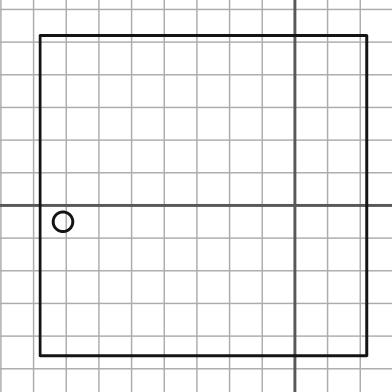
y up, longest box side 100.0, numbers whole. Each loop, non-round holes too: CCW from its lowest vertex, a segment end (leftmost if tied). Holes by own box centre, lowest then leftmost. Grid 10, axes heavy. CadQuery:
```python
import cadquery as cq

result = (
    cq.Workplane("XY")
    .moveTo(-78.0, -46.0)
    .lineTo(22.0, -46.0)
    .lineTo(22.0, 52.0)
    .lineTo(-78.0, 52.0)
    .close()
    .moveTo(-71.0, -5.0)
    .circle(3.0)
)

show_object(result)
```